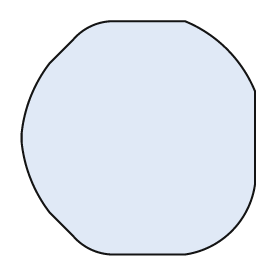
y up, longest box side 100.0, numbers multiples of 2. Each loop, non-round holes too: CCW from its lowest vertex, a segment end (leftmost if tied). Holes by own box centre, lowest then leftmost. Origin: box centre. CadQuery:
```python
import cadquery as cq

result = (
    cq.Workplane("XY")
    .moveTo(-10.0, -50.0)
    .lineTo(20.0, -50.0)
    .threePointArc((40.0, -40.0), (50.0, -20.0))
    .lineTo(50.0, 20.0)
    .threePointArc((38.0, 38.0), (20.0, 50.0))
    .lineTo(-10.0, 50.0)
    .threePointArc((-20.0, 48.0), (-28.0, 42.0))
    .lineTo(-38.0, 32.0)
    .threePointArc((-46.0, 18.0), (-50.0, 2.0))
    .lineTo(-50.0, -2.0)
    .threePointArc((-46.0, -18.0), (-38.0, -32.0))
    .lineTo(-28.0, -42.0)
    .threePointArc((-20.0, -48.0), (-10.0, -50.0))
    .close()
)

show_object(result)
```